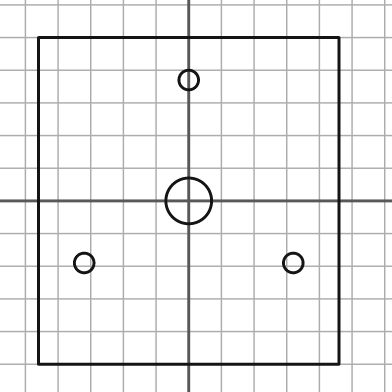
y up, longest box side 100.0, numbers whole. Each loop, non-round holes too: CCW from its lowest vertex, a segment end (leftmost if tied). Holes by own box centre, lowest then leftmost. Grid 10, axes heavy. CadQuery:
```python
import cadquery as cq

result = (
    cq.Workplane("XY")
    .moveTo(-46.0, -50.0)
    .lineTo(46.0, -50.0)
    .lineTo(46.0, 50.0)
    .lineTo(-46.0, 50.0)
    .close()
    .moveTo(-32.0, -19.0)
    .circle(3.0)
    .moveTo(32.0, -19.0)
    .circle(3.0)
    .moveTo(0.0, 0.0)
    .circle(7.0)
    .moveTo(0.0, 37.0)
    .circle(3.0)
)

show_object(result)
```